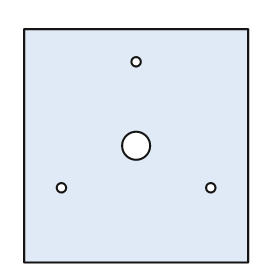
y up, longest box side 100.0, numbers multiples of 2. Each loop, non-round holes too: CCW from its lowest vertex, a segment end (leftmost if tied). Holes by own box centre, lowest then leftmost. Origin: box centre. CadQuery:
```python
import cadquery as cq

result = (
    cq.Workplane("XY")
    .moveTo(-48.0, -50.0)
    .lineTo(48.0, -50.0)
    .lineTo(48.0, 50.0)
    .lineTo(-48.0, 50.0)
    .close()
    .moveTo(-32.0, -18.0)
    .circle(2.0)
    .moveTo(32.0, -18.0)
    .circle(2.0)
    .moveTo(0.0, 0.0)
    .circle(6.0)
    .moveTo(0.0, 36.0)
    .circle(2.0)
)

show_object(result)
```